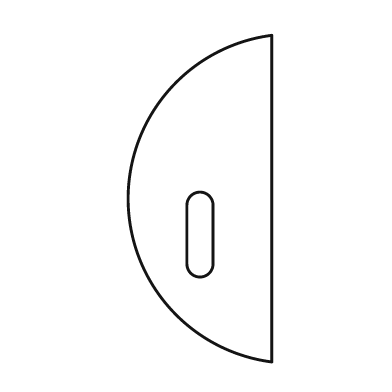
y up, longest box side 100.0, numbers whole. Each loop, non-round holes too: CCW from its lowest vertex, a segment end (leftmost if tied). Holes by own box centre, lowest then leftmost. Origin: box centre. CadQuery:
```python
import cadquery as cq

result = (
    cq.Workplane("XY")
    .moveTo(22.0, -50.0)
    .lineTo(22.0, 50.0)
    .threePointArc((-22.0, 0.0), (22.0, -50.0))
    .close()
    .moveTo(-4.0, -20.0)
    .threePointArc((0.0, -24.0), (4.0, -20.0))
    .lineTo(4.0, -2.0)
    .threePointArc((0.0, 2.0), (-4.0, -2.0))
    .close()
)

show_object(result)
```